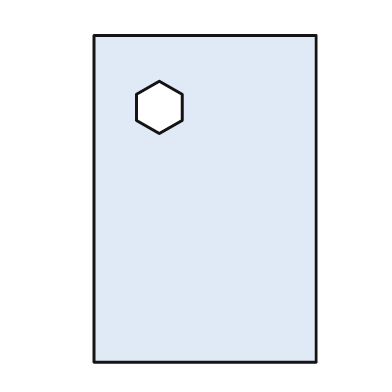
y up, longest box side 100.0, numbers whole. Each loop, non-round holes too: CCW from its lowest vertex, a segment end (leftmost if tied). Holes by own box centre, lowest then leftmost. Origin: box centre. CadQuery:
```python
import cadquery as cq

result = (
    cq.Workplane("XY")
    .moveTo(-34.0, -50.0)
    .lineTo(34.0, -50.0)
    .lineTo(34.0, 50.0)
    .lineTo(-34.0, 50.0)
    .close()
    .moveTo(-14.0, 20.0)
    .lineTo(-7.0, 24.0)
    .lineTo(-7.0, 32.0)
    .lineTo(-14.0, 36.0)
    .lineTo(-21.0, 32.0)
    .lineTo(-21.0, 24.0)
    .close()
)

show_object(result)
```